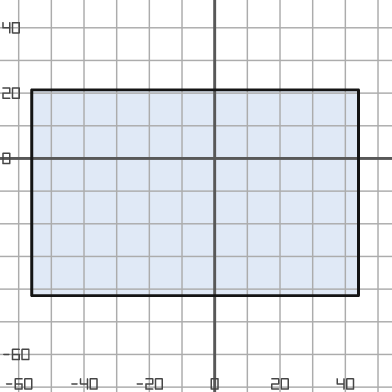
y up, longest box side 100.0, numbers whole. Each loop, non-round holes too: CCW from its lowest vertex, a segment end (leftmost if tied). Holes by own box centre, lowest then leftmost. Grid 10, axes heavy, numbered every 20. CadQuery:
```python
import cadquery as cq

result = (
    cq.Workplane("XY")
    .moveTo(-56.0, -42.0)
    .lineTo(44.0, -42.0)
    .lineTo(44.0, 21.0)
    .lineTo(-56.0, 21.0)
    .close()
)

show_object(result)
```